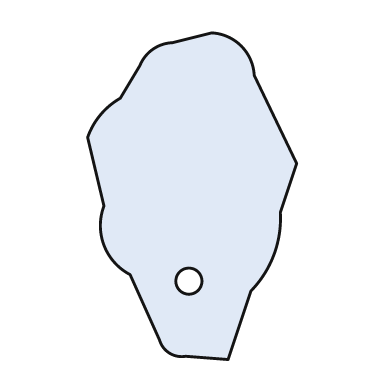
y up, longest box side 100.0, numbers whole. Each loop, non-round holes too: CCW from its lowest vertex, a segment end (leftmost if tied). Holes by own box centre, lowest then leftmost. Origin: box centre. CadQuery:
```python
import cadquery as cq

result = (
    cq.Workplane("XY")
    .moveTo(11.0, -50.0)
    .lineTo(18.0, -29.0)
    .threePointArc((25.0, -18.0), (27.0, -5.0))
    .lineTo(32.0, 10.0)
    .lineTo(19.0, 37.0)
    .threePointArc((15.0, 46.0), (6.0, 50.0))
    .lineTo(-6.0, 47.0)
    .threePointArc((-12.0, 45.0), (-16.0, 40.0))
    .lineTo(-22.0, 30.0)
    .threePointArc((-28.0, 25.0), (-32.0, 18.0))
    .lineTo(-27.0, -3.0)
    .threePointArc((-27.0, -15.0), (-19.0, -24.0))
    .lineTo(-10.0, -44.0)
    .threePointArc((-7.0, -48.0), (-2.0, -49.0))
    .close()
    .moveTo(-1.0, -26.0)
    .circle(4.0)
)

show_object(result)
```